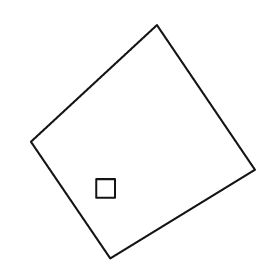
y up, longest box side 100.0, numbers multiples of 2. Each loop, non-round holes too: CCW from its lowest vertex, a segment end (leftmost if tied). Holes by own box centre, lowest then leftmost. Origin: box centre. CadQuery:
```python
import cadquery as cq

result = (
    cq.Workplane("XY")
    .moveTo(-14.0, -50.0)
    .lineTo(48.0, -12.0)
    .lineTo(6.0, 50.0)
    .lineTo(-48.0, 0.0)
    .close()
    .moveTo(-20.0, -24.0)
    .lineTo(-12.0, -24.0)
    .lineTo(-12.0, -16.0)
    .lineTo(-20.0, -16.0)
    .close()
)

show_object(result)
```